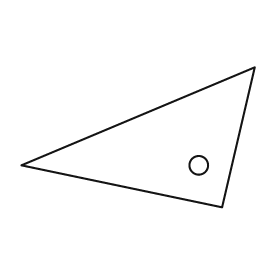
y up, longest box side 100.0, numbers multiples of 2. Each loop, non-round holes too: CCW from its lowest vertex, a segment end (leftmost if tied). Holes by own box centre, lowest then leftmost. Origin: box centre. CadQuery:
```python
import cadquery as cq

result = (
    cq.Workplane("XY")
    .moveTo(36.0, -30.0)
    .lineTo(50.0, 30.0)
    .lineTo(-50.0, -12.0)
    .close()
    .moveTo(26.0, -12.0)
    .circle(4.0)
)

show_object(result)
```